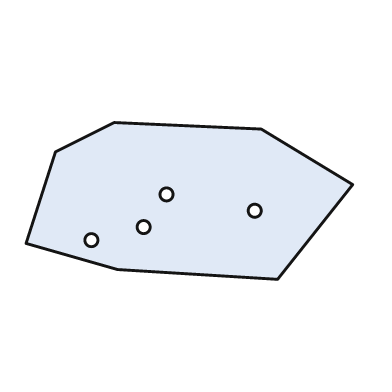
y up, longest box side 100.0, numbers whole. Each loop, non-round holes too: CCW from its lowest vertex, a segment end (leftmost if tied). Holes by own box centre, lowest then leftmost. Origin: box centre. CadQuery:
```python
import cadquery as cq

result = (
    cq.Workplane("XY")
    .moveTo(27.0, -24.0)
    .lineTo(50.0, 5.0)
    .lineTo(22.0, 22.0)
    .lineTo(-23.0, 24.0)
    .lineTo(-41.0, 15.0)
    .lineTo(-50.0, -13.0)
    .lineTo(-22.0, -21.0)
    .close()
    .moveTo(-30.0, -12.0)
    .circle(2.0)
    .moveTo(-14.0, -8.0)
    .circle(2.0)
    .moveTo(20.0, -3.0)
    .circle(2.0)
    .moveTo(-7.0, 2.0)
    .circle(2.0)
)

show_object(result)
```